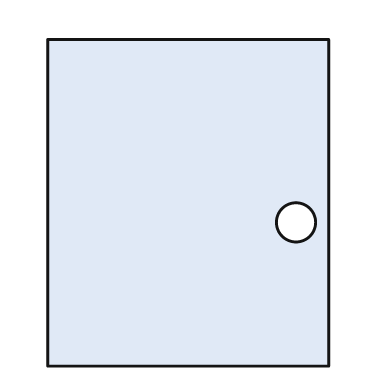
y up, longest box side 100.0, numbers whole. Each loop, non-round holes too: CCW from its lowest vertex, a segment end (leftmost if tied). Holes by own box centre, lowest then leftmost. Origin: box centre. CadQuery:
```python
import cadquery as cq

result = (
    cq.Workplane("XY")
    .moveTo(-43.0, -50.0)
    .lineTo(43.0, -50.0)
    .lineTo(43.0, 50.0)
    .lineTo(-43.0, 50.0)
    .close()
    .moveTo(33.0, -6.0)
    .circle(6.0)
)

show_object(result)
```